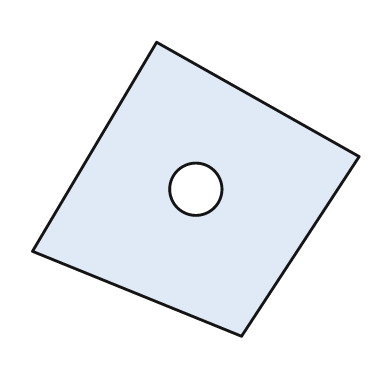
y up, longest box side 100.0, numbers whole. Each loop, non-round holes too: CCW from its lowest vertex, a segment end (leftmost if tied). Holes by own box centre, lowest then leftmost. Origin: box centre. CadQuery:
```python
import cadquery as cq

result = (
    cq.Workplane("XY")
    .moveTo(14.0, -45.0)
    .lineTo(50.0, 10.0)
    .lineTo(-12.0, 45.0)
    .lineTo(-50.0, -19.0)
    .close()
    .moveTo(0.0, 0.0)
    .circle(8.0)
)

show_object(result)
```